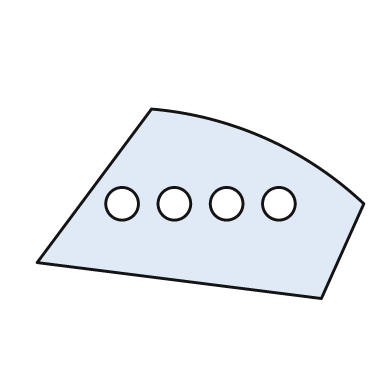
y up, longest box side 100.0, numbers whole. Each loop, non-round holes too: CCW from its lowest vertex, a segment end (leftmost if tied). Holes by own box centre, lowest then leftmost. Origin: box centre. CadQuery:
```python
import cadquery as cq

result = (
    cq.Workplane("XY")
    .moveTo(37.0, -29.0)
    .lineTo(50.0, 0.0)
    .threePointArc((20.0, 20.0), (-15.0, 29.0))
    .lineTo(-50.0, -18.0)
    .close()
    .moveTo(-24.0, 0.0)
    .circle(5.0)
    .moveTo(-8.0, 0.0)
    .circle(5.0)
    .moveTo(8.0, 0.0)
    .circle(5.0)
    .moveTo(24.0, 0.0)
    .circle(5.0)
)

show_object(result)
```